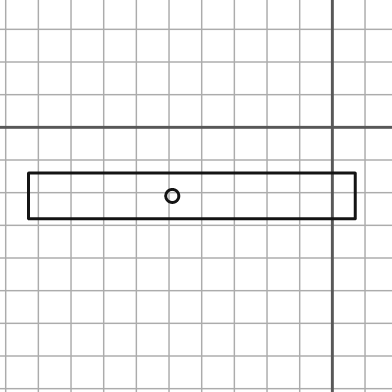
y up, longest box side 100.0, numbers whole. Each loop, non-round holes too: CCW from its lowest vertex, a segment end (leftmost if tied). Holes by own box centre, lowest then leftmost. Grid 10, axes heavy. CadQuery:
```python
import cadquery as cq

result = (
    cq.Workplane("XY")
    .moveTo(-93.0, -28.0)
    .lineTo(7.0, -28.0)
    .lineTo(7.0, -14.0)
    .lineTo(-93.0, -14.0)
    .close()
    .moveTo(-49.0, -21.0)
    .circle(2.0)
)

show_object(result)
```